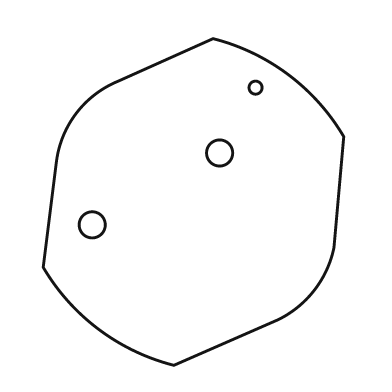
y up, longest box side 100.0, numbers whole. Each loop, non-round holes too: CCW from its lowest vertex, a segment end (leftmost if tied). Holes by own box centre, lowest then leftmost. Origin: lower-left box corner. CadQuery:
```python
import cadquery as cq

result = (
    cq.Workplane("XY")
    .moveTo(40.0, 0.0)
    .lineTo(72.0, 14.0)
    .threePointArc((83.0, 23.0), (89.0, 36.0))
    .lineTo(92.0, 70.0)
    .threePointArc((75.0, 89.0), (52.0, 100.0))
    .lineTo(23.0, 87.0)
    .threePointArc((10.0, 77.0), (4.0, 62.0))
    .lineTo(0.0, 30.0)
    .threePointArc((17.0, 11.0), (40.0, 0.0))
    .close()
    .moveTo(15.0, 43.0)
    .circle(4.0)
    .moveTo(54.0, 65.0)
    .circle(4.0)
    .moveTo(65.0, 85.0)
    .circle(2.0)
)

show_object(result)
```